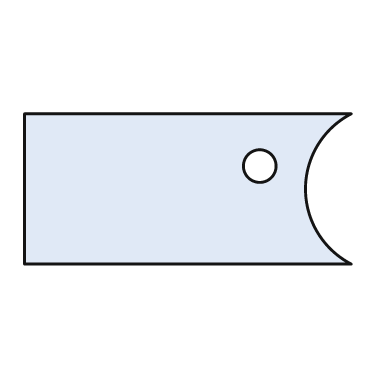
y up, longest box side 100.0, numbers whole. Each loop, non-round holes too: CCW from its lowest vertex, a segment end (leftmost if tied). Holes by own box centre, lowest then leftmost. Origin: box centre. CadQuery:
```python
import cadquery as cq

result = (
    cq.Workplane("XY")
    .moveTo(-50.0, -23.0)
    .lineTo(50.0, -23.0)
    .threePointArc((36.0, 0.0), (50.0, 23.0))
    .lineTo(-50.0, 23.0)
    .close()
    .moveTo(22.0, 7.0)
    .circle(5.0)
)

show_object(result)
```